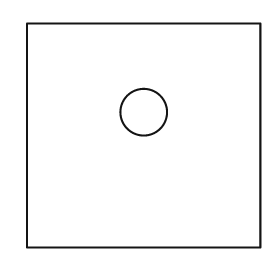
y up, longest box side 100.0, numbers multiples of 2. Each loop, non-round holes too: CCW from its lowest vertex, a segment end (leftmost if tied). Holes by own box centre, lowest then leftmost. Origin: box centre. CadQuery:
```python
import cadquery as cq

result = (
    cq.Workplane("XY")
    .moveTo(-50.0, -48.0)
    .lineTo(50.0, -48.0)
    .lineTo(50.0, 48.0)
    .lineTo(-50.0, 48.0)
    .close()
    .moveTo(0.0, 10.0)
    .circle(10.0)
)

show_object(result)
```